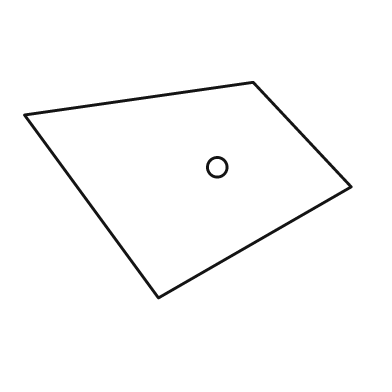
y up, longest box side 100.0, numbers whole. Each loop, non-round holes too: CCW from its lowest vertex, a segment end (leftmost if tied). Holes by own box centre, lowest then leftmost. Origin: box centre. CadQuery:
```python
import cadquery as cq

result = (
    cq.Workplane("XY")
    .moveTo(-9.0, -33.0)
    .lineTo(50.0, 1.0)
    .lineTo(20.0, 33.0)
    .lineTo(-50.0, 23.0)
    .close()
    .moveTo(9.0, 7.0)
    .circle(3.0)
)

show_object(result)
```